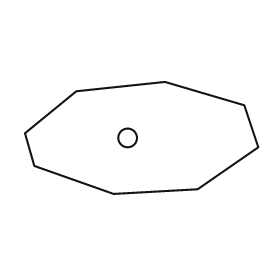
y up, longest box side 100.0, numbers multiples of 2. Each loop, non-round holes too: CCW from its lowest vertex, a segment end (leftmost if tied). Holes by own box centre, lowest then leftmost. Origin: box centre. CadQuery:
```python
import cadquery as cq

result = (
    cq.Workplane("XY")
    .moveTo(-12.0, -24.0)
    .lineTo(24.0, -22.0)
    .lineTo(50.0, -4.0)
    .lineTo(44.0, 14.0)
    .lineTo(10.0, 24.0)
    .lineTo(-28.0, 20.0)
    .lineTo(-50.0, 2.0)
    .lineTo(-46.0, -12.0)
    .close()
    .moveTo(-6.0, 0.0)
    .circle(4.0)
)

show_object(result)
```